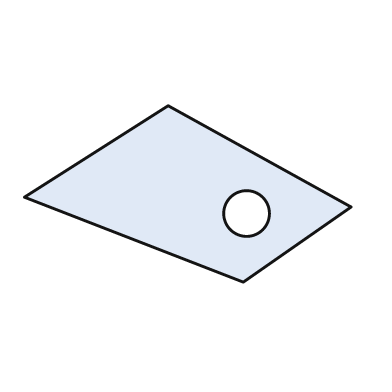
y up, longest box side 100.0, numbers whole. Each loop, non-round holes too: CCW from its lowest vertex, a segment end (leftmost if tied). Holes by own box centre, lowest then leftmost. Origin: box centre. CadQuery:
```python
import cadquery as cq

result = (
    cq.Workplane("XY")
    .moveTo(17.0, -27.0)
    .lineTo(50.0, -4.0)
    .lineTo(-6.0, 27.0)
    .lineTo(-50.0, -1.0)
    .close()
    .moveTo(18.0, -6.0)
    .circle(7.0)
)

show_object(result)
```